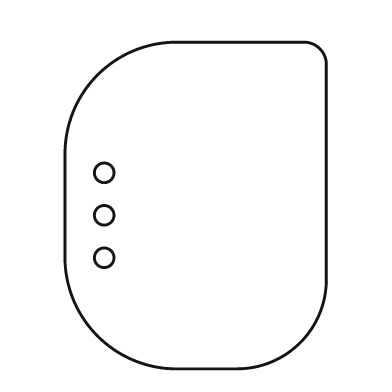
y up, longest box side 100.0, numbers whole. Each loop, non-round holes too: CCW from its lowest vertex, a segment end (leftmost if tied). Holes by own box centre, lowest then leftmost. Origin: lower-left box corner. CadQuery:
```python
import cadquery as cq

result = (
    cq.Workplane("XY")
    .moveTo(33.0, 0.0)
    .lineTo(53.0, 0.0)
    .threePointArc((72.0, 8.0), (80.0, 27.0))
    .lineTo(80.0, 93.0)
    .threePointArc((78.0, 98.0), (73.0, 100.0))
    .lineTo(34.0, 100.0)
    .threePointArc((10.0, 90.0), (0.0, 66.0))
    .lineTo(0.0, 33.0)
    .threePointArc((10.0, 10.0), (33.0, 0.0))
    .close()
    .moveTo(12.0, 34.0)
    .circle(3.0)
    .moveTo(12.0, 47.0)
    .circle(3.0)
    .moveTo(12.0, 60.0)
    .circle(3.0)
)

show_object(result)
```